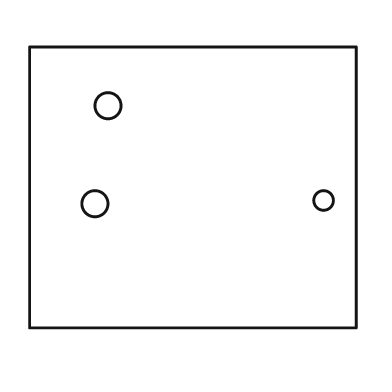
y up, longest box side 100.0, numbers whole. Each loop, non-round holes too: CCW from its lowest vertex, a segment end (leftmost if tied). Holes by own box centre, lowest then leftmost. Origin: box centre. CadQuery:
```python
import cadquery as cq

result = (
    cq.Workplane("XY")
    .moveTo(-50.0, -43.0)
    .lineTo(50.0, -43.0)
    .lineTo(50.0, 43.0)
    .lineTo(-50.0, 43.0)
    .close()
    .moveTo(-30.0, -5.0)
    .circle(4.0)
    .moveTo(40.0, -4.0)
    .circle(3.0)
    .moveTo(-26.0, 25.0)
    .circle(4.0)
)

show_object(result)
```